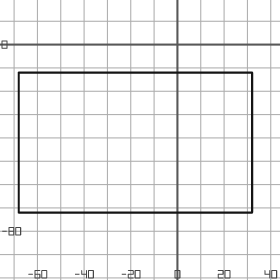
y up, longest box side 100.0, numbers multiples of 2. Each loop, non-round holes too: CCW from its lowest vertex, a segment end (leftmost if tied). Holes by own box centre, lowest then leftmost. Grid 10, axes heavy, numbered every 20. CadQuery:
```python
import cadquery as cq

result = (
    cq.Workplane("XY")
    .moveTo(-68.0, -72.0)
    .lineTo(32.0, -72.0)
    .lineTo(32.0, -12.0)
    .lineTo(-68.0, -12.0)
    .close()
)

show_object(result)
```